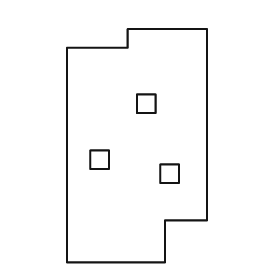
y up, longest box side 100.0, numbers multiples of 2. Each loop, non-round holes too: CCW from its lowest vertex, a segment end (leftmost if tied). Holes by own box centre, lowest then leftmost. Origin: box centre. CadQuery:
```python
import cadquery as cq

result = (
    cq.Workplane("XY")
    .moveTo(-30.0, -50.0)
    .lineTo(12.0, -50.0)
    .lineTo(12.0, -32.0)
    .lineTo(30.0, -32.0)
    .lineTo(30.0, 50.0)
    .lineTo(-4.0, 50.0)
    .lineTo(-4.0, 42.0)
    .lineTo(-30.0, 42.0)
    .close()
    .moveTo(10.0, -16.0)
    .lineTo(18.0, -16.0)
    .lineTo(18.0, -8.0)
    .lineTo(10.0, -8.0)
    .close()
    .moveTo(-20.0, -10.0)
    .lineTo(-12.0, -10.0)
    .lineTo(-12.0, -2.0)
    .lineTo(-20.0, -2.0)
    .close()
    .moveTo(0.0, 14.0)
    .lineTo(8.0, 14.0)
    .lineTo(8.0, 22.0)
    .lineTo(0.0, 22.0)
    .close()
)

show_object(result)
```